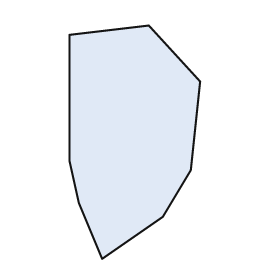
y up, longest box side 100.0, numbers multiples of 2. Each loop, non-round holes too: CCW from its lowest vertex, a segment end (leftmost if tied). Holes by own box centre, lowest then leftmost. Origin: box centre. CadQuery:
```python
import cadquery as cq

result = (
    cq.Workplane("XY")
    .moveTo(-14.0, -50.0)
    .lineTo(12.0, -32.0)
    .lineTo(24.0, -12.0)
    .lineTo(28.0, 26.0)
    .lineTo(6.0, 50.0)
    .lineTo(-28.0, 46.0)
    .lineTo(-28.0, -8.0)
    .lineTo(-24.0, -26.0)
    .close()
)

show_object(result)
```